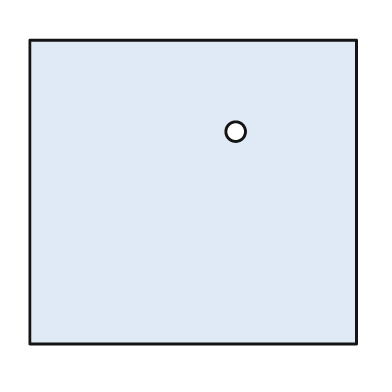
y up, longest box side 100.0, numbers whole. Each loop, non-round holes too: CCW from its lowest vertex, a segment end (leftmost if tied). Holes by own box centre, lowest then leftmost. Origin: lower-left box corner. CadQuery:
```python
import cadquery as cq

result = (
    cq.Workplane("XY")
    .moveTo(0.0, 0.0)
    .lineTo(100.0, 0.0)
    .lineTo(100.0, 93.0)
    .lineTo(0.0, 93.0)
    .close()
    .moveTo(63.0, 65.0)
    .circle(3.0)
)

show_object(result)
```